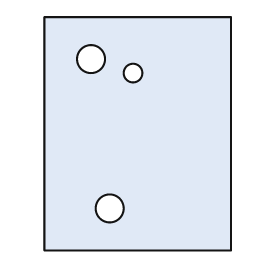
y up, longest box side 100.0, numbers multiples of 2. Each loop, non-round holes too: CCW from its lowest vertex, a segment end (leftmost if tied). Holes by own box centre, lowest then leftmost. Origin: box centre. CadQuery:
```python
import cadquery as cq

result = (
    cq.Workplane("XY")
    .moveTo(-40.0, -50.0)
    .lineTo(40.0, -50.0)
    .lineTo(40.0, 50.0)
    .lineTo(-40.0, 50.0)
    .close()
    .moveTo(-12.0, -32.0)
    .circle(6.0)
    .moveTo(-2.0, 26.0)
    .circle(4.0)
    .moveTo(-20.0, 32.0)
    .circle(6.0)
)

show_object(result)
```